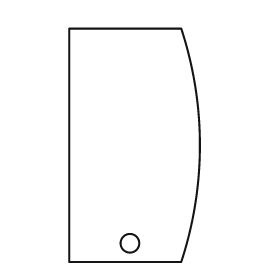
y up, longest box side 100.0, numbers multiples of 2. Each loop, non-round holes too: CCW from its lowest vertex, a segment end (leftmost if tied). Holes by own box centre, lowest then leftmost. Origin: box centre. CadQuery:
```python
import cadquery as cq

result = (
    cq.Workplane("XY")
    .moveTo(-28.0, -50.0)
    .lineTo(20.0, -50.0)
    .threePointArc((28.0, 0.0), (20.0, 50.0))
    .lineTo(-28.0, 50.0)
    .close()
    .moveTo(-2.0, -42.0)
    .circle(4.0)
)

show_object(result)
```